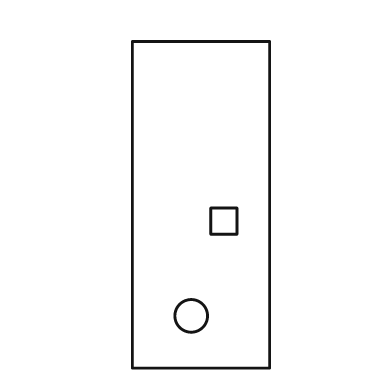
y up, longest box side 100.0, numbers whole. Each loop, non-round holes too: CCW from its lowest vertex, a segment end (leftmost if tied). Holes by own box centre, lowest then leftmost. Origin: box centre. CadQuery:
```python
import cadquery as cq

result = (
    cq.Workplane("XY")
    .moveTo(-21.0, -50.0)
    .lineTo(21.0, -50.0)
    .lineTo(21.0, 50.0)
    .lineTo(-21.0, 50.0)
    .close()
    .moveTo(-3.0, -34.0)
    .circle(5.0)
    .moveTo(3.0, -9.0)
    .lineTo(11.0, -9.0)
    .lineTo(11.0, -1.0)
    .lineTo(3.0, -1.0)
    .close()
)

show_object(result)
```